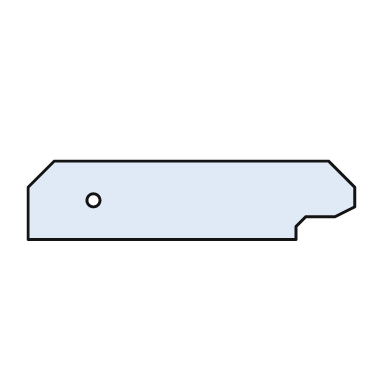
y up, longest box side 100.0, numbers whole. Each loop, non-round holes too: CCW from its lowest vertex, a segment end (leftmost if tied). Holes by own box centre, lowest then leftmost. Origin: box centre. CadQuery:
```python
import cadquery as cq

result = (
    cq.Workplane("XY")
    .moveTo(-50.0, -12.0)
    .lineTo(32.0, -12.0)
    .lineTo(32.0, -8.0)
    .lineTo(35.0, -5.0)
    .lineTo(44.0, -5.0)
    .lineTo(50.0, -2.0)
    .lineTo(50.0, 4.0)
    .lineTo(42.0, 12.0)
    .lineTo(-42.0, 12.0)
    .lineTo(-50.0, 4.0)
    .close()
    .moveTo(-30.0, 0.0)
    .circle(2.0)
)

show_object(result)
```